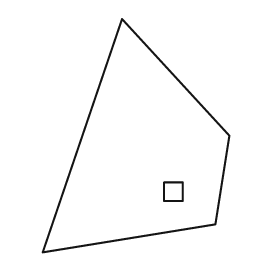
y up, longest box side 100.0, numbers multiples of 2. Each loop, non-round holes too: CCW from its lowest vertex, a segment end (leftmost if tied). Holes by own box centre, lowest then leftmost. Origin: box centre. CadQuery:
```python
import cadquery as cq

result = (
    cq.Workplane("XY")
    .moveTo(-40.0, -50.0)
    .lineTo(34.0, -38.0)
    .lineTo(40.0, 0.0)
    .lineTo(-6.0, 50.0)
    .close()
    .moveTo(12.0, -28.0)
    .lineTo(20.0, -28.0)
    .lineTo(20.0, -20.0)
    .lineTo(12.0, -20.0)
    .close()
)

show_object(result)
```